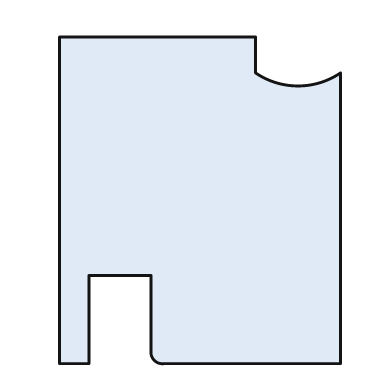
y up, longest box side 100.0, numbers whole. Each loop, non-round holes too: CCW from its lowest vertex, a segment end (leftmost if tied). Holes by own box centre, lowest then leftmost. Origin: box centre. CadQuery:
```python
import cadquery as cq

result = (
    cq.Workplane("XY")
    .moveTo(-43.0, -50.0)
    .lineTo(-34.0, -50.0)
    .lineTo(-34.0, -23.0)
    .lineTo(-15.0, -23.0)
    .lineTo(-15.0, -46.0)
    .threePointArc((-14.0, -49.0), (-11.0, -50.0))
    .lineTo(43.0, -50.0)
    .lineTo(43.0, 39.0)
    .threePointArc((30.0, 35.0), (17.0, 39.0))
    .lineTo(17.0, 50.0)
    .lineTo(-43.0, 50.0)
    .close()
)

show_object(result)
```